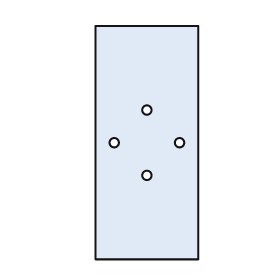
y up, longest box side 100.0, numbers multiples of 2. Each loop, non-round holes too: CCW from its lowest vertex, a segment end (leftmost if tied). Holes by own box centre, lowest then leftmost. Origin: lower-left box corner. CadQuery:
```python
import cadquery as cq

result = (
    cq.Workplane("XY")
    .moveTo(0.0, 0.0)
    .lineTo(44.0, 0.0)
    .lineTo(44.0, 100.0)
    .lineTo(0.0, 100.0)
    .close()
    .moveTo(22.0, 36.0)
    .circle(2.0)
    .moveTo(8.0, 50.0)
    .circle(2.0)
    .moveTo(36.0, 50.0)
    .circle(2.0)
    .moveTo(22.0, 64.0)
    .circle(2.0)
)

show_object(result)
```